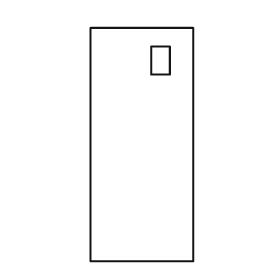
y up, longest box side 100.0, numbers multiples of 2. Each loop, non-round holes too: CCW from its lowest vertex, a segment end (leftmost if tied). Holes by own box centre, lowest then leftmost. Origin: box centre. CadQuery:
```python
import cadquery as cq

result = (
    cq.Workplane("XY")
    .moveTo(-22.0, -50.0)
    .lineTo(22.0, -50.0)
    .lineTo(22.0, 50.0)
    .lineTo(-22.0, 50.0)
    .close()
    .moveTo(4.0, 30.0)
    .lineTo(12.0, 30.0)
    .lineTo(12.0, 42.0)
    .lineTo(4.0, 42.0)
    .close()
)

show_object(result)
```